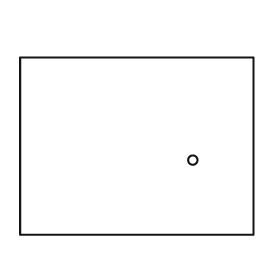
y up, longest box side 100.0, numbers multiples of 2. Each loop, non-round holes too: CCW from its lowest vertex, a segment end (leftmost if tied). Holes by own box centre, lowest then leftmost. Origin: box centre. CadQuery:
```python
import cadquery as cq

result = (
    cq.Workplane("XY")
    .moveTo(-50.0, -38.0)
    .lineTo(50.0, -38.0)
    .lineTo(50.0, 38.0)
    .lineTo(-50.0, 38.0)
    .close()
    .moveTo(24.0, -6.0)
    .circle(2.0)
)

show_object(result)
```